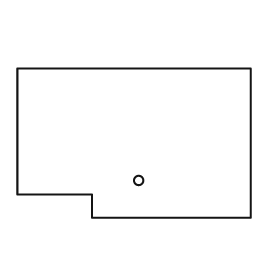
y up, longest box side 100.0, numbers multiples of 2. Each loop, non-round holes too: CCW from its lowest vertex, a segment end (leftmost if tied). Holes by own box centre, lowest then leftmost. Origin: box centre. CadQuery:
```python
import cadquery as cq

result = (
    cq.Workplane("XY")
    .moveTo(-18.0, -32.0)
    .lineTo(50.0, -32.0)
    .lineTo(50.0, 32.0)
    .lineTo(-50.0, 32.0)
    .lineTo(-50.0, -22.0)
    .lineTo(-18.0, -22.0)
    .close()
    .moveTo(2.0, -16.0)
    .circle(2.0)
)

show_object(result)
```